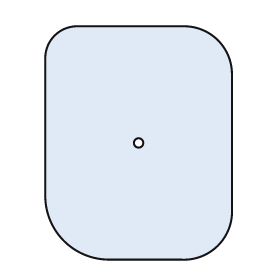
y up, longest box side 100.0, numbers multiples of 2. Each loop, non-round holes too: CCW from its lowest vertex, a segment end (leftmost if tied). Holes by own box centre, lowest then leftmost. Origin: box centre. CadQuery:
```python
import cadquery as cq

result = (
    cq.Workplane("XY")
    .moveTo(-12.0, -50.0)
    .lineTo(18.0, -50.0)
    .threePointArc((34.0, -44.0), (40.0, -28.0))
    .lineTo(40.0, 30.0)
    .threePointArc((34.0, 44.0), (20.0, 50.0))
    .lineTo(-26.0, 50.0)
    .threePointArc((-36.0, 46.0), (-40.0, 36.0))
    .lineTo(-40.0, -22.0)
    .threePointArc((-32.0, -42.0), (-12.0, -50.0))
    .close()
    .moveTo(0.0, 0.0)
    .circle(2.0)
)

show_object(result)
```